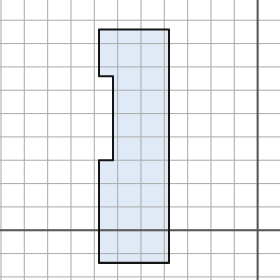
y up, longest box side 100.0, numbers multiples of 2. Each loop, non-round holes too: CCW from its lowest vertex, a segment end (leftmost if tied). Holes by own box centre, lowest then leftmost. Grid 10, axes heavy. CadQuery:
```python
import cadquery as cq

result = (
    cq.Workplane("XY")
    .moveTo(-68.0, -14.0)
    .lineTo(-38.0, -14.0)
    .lineTo(-38.0, 86.0)
    .lineTo(-68.0, 86.0)
    .lineTo(-68.0, 66.0)
    .lineTo(-62.0, 66.0)
    .lineTo(-62.0, 30.0)
    .lineTo(-68.0, 30.0)
    .close()
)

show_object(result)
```